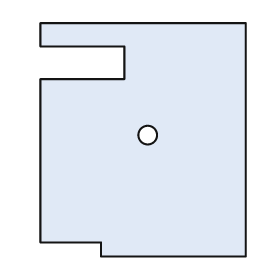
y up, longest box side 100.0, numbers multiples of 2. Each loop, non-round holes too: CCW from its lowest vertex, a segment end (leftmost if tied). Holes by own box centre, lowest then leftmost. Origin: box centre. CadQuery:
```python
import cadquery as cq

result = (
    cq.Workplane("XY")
    .moveTo(-18.0, -50.0)
    .lineTo(44.0, -50.0)
    .lineTo(44.0, 50.0)
    .lineTo(-44.0, 50.0)
    .lineTo(-44.0, 40.0)
    .lineTo(-8.0, 40.0)
    .lineTo(-8.0, 26.0)
    .lineTo(-44.0, 26.0)
    .lineTo(-44.0, -44.0)
    .lineTo(-18.0, -44.0)
    .close()
    .moveTo(2.0, 2.0)
    .circle(4.0)
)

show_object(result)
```